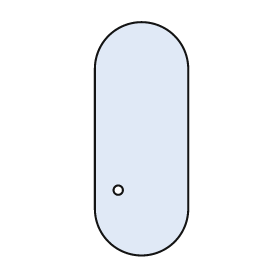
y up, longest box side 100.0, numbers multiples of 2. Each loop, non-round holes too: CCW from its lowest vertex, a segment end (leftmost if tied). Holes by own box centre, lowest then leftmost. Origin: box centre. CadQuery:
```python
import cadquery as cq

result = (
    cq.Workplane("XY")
    .moveTo(-20.0, -30.0)
    .threePointArc((0.0, -50.0), (20.0, -30.0))
    .lineTo(20.0, 30.0)
    .threePointArc((0.0, 50.0), (-20.0, 30.0))
    .close()
    .moveTo(-10.0, -22.0)
    .circle(2.0)
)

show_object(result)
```